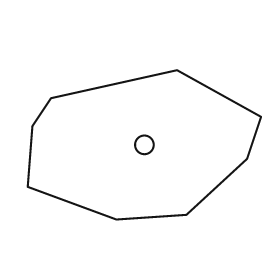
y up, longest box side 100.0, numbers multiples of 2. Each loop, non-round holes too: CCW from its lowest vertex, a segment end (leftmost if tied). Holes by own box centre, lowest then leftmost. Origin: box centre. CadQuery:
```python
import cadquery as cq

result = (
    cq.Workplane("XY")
    .moveTo(-12.0, -32.0)
    .lineTo(18.0, -30.0)
    .lineTo(44.0, -6.0)
    .lineTo(50.0, 12.0)
    .lineTo(14.0, 32.0)
    .lineTo(-40.0, 20.0)
    .lineTo(-48.0, 8.0)
    .lineTo(-50.0, -18.0)
    .close()
    .moveTo(0.0, 0.0)
    .circle(4.0)
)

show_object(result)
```